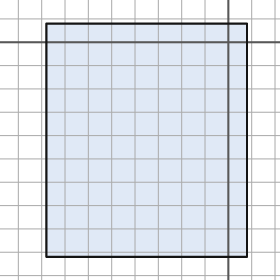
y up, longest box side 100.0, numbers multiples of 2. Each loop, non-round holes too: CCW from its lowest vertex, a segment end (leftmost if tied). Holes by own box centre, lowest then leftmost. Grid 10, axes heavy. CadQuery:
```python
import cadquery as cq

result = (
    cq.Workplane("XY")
    .moveTo(-78.0, -92.0)
    .lineTo(8.0, -92.0)
    .lineTo(8.0, 8.0)
    .lineTo(-78.0, 8.0)
    .close()
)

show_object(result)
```